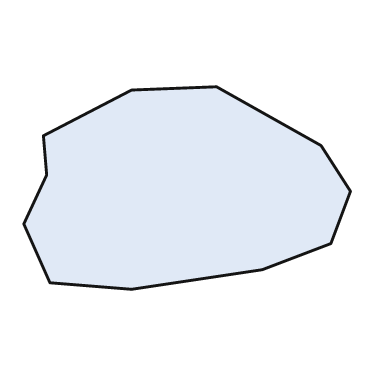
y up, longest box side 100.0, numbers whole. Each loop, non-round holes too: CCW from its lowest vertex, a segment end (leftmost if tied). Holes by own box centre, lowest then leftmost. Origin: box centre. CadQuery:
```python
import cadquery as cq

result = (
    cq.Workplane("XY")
    .moveTo(-17.0, -31.0)
    .lineTo(23.0, -25.0)
    .lineTo(44.0, -17.0)
    .lineTo(50.0, -1.0)
    .lineTo(41.0, 13.0)
    .lineTo(9.0, 31.0)
    .lineTo(-17.0, 30.0)
    .lineTo(-44.0, 16.0)
    .lineTo(-43.0, 4.0)
    .lineTo(-50.0, -11.0)
    .lineTo(-42.0, -29.0)
    .close()
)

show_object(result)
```